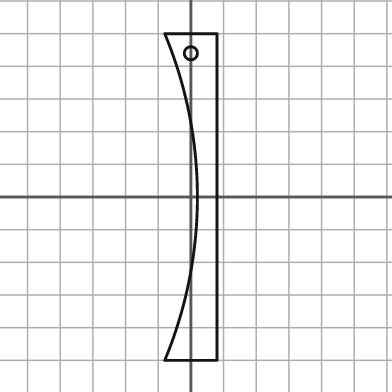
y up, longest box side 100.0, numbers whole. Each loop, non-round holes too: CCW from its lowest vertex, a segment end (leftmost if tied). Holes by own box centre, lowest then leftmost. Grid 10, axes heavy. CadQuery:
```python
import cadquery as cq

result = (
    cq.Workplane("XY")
    .moveTo(-8.0, -50.0)
    .lineTo(8.0, -50.0)
    .lineTo(8.0, 50.0)
    .lineTo(-8.0, 50.0)
    .threePointArc((2.0, 0.0), (-8.0, -50.0))
    .close()
    .moveTo(0.0, 44.0)
    .circle(2.0)
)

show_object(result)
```